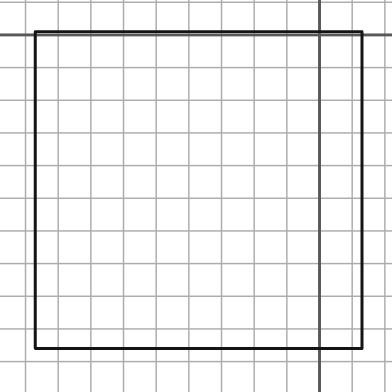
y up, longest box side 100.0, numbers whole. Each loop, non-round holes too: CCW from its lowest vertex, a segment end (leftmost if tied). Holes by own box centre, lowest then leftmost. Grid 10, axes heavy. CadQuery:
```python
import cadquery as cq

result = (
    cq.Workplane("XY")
    .moveTo(-87.0, -96.0)
    .lineTo(13.0, -96.0)
    .lineTo(13.0, 1.0)
    .lineTo(-87.0, 1.0)
    .close()
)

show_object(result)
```